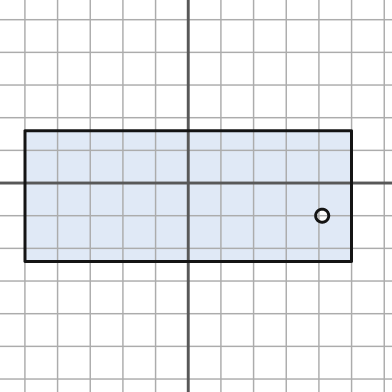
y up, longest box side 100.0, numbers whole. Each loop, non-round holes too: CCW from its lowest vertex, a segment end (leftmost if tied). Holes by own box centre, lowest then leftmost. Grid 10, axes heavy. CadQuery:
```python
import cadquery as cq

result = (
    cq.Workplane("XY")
    .moveTo(-50.0, -24.0)
    .lineTo(50.0, -24.0)
    .lineTo(50.0, 16.0)
    .lineTo(-50.0, 16.0)
    .close()
    .moveTo(41.0, -10.0)
    .circle(2.0)
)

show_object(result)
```